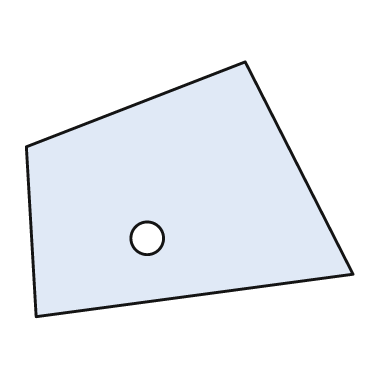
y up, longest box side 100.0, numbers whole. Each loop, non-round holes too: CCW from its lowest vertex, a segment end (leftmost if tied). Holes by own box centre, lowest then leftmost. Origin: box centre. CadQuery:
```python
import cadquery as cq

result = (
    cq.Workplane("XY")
    .moveTo(-47.0, -39.0)
    .lineTo(50.0, -26.0)
    .lineTo(17.0, 39.0)
    .lineTo(-50.0, 13.0)
    .close()
    .moveTo(-13.0, -15.0)
    .circle(5.0)
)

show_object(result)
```